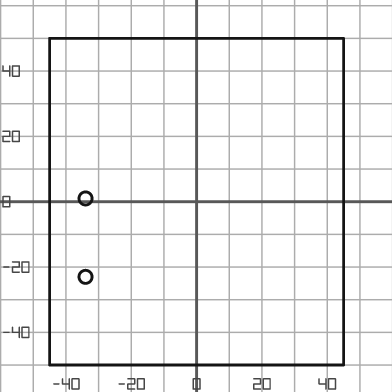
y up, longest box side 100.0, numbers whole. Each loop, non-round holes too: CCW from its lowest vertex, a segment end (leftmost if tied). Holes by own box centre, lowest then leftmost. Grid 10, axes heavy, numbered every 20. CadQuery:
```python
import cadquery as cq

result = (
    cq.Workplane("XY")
    .moveTo(-45.0, -50.0)
    .lineTo(45.0, -50.0)
    .lineTo(45.0, 50.0)
    .lineTo(-45.0, 50.0)
    .close()
    .moveTo(-34.0, -23.0)
    .circle(2.0)
    .moveTo(-34.0, 1.0)
    .circle(2.0)
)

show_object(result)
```